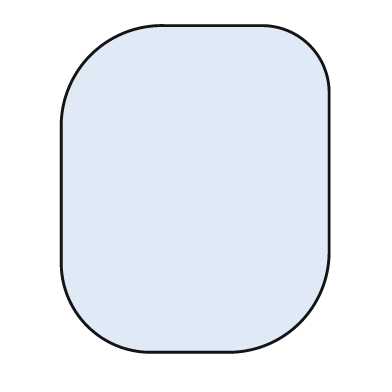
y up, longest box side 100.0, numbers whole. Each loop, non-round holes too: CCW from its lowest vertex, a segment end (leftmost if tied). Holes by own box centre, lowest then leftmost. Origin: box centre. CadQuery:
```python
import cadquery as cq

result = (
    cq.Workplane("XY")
    .moveTo(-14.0, -50.0)
    .lineTo(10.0, -50.0)
    .threePointArc((32.0, -41.0), (41.0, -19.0))
    .lineTo(41.0, 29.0)
    .threePointArc((35.0, 44.0), (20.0, 50.0))
    .lineTo(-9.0, 50.0)
    .threePointArc((-32.0, 41.0), (-41.0, 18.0))
    .lineTo(-41.0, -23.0)
    .threePointArc((-33.0, -42.0), (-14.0, -50.0))
    .close()
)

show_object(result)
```